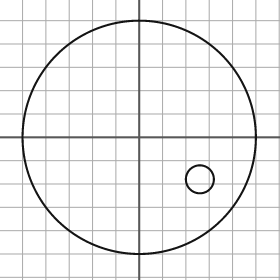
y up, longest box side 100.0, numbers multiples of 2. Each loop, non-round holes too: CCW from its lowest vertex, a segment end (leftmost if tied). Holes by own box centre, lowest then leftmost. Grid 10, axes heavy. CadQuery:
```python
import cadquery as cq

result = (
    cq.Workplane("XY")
    .moveTo(0.0, 0.0)
    .circle(50.0)
    .moveTo(26.0, -18.0)
    .circle(6.0)
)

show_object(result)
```